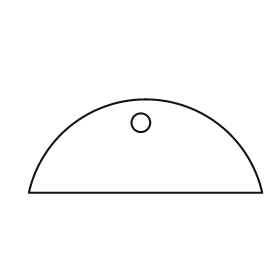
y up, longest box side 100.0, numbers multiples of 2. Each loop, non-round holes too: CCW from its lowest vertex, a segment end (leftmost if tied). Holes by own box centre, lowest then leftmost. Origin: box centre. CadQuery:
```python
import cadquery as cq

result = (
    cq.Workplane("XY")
    .moveTo(-50.0, -20.0)
    .lineTo(50.0, -20.0)
    .threePointArc((0.0, 20.0), (-50.0, -20.0))
    .close()
    .moveTo(-2.0, 10.0)
    .circle(4.0)
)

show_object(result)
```